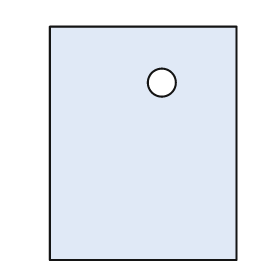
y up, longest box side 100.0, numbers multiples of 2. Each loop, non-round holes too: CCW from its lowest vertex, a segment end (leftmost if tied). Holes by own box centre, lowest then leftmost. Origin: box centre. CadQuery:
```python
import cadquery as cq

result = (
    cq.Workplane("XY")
    .moveTo(-40.0, -50.0)
    .lineTo(40.0, -50.0)
    .lineTo(40.0, 50.0)
    .lineTo(-40.0, 50.0)
    .close()
    .moveTo(8.0, 26.0)
    .circle(6.0)
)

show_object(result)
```